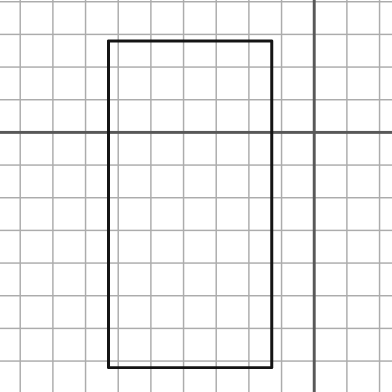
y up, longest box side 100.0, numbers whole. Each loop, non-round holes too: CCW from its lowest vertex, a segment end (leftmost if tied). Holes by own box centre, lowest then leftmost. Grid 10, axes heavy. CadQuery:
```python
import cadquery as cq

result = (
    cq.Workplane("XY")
    .moveTo(-63.0, -72.0)
    .lineTo(-13.0, -72.0)
    .lineTo(-13.0, 28.0)
    .lineTo(-63.0, 28.0)
    .close()
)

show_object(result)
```